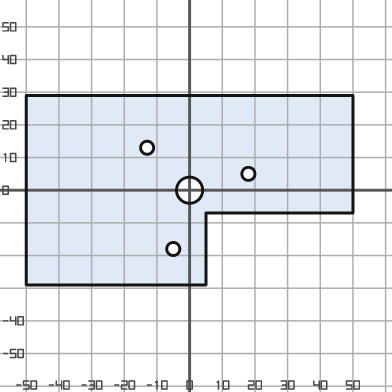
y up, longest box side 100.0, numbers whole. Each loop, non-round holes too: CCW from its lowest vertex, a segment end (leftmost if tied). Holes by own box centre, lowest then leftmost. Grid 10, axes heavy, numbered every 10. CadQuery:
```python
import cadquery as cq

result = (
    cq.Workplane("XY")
    .moveTo(-50.0, -29.0)
    .lineTo(5.0, -29.0)
    .lineTo(5.0, -7.0)
    .lineTo(50.0, -7.0)
    .lineTo(50.0, 29.0)
    .lineTo(-50.0, 29.0)
    .close()
    .moveTo(-5.0, -18.0)
    .circle(2.0)
    .moveTo(0.0, 0.0)
    .circle(4.0)
    .moveTo(18.0, 5.0)
    .circle(2.0)
    .moveTo(-13.0, 13.0)
    .circle(2.0)
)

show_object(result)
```